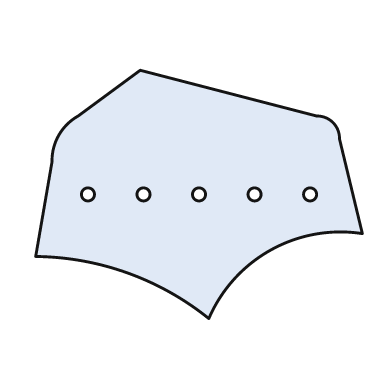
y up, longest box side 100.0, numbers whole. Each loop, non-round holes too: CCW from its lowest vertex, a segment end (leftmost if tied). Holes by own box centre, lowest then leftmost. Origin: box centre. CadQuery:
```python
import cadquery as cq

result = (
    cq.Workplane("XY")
    .moveTo(3.0, -38.0)
    .threePointArc((22.0, -17.0), (50.0, -12.0))
    .lineTo(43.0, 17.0)
    .threePointArc((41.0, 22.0), (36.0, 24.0))
    .lineTo(-18.0, 38.0)
    .lineTo(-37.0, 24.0)
    .threePointArc((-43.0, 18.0), (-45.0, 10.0))
    .lineTo(-50.0, -19.0)
    .threePointArc((-22.0, -24.0), (3.0, -38.0))
    .close()
    .moveTo(-34.0, 0.0)
    .circle(2.0)
    .moveTo(-17.0, 0.0)
    .circle(2.0)
    .moveTo(0.0, 0.0)
    .circle(2.0)
    .moveTo(17.0, 0.0)
    .circle(2.0)
    .moveTo(34.0, 0.0)
    .circle(2.0)
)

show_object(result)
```